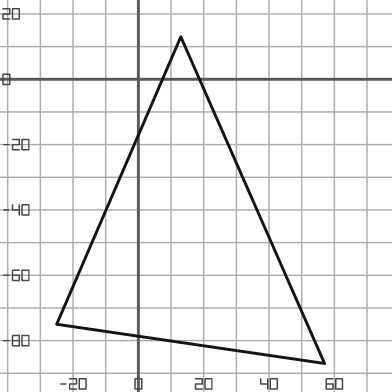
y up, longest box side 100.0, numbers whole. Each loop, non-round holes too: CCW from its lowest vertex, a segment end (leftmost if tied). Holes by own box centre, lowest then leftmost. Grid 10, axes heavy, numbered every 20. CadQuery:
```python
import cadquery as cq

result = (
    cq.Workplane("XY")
    .moveTo(57.0, -87.0)
    .lineTo(13.0, 13.0)
    .lineTo(-25.0, -75.0)
    .close()
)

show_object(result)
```